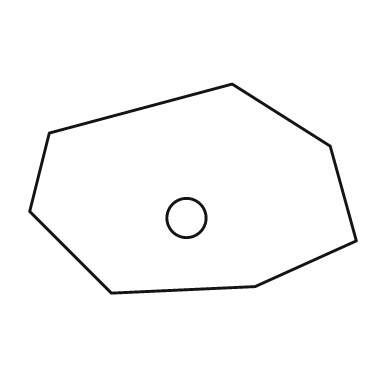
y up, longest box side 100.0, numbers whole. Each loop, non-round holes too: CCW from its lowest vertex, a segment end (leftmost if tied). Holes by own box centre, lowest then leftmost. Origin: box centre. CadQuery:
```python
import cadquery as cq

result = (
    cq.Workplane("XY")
    .moveTo(-25.0, -32.0)
    .lineTo(19.0, -30.0)
    .lineTo(50.0, -16.0)
    .lineTo(42.0, 13.0)
    .lineTo(12.0, 32.0)
    .lineTo(-44.0, 17.0)
    .lineTo(-50.0, -7.0)
    .close()
    .moveTo(-2.0, -9.0)
    .circle(6.0)
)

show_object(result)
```